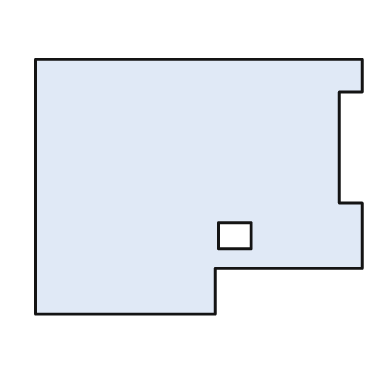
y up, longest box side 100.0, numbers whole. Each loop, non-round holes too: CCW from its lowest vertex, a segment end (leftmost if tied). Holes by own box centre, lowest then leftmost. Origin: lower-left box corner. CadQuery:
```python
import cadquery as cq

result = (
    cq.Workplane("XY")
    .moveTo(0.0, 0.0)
    .lineTo(55.0, 0.0)
    .lineTo(55.0, 14.0)
    .lineTo(100.0, 14.0)
    .lineTo(100.0, 34.0)
    .lineTo(93.0, 34.0)
    .lineTo(93.0, 68.0)
    .lineTo(100.0, 68.0)
    .lineTo(100.0, 78.0)
    .lineTo(0.0, 78.0)
    .close()
    .moveTo(56.0, 20.0)
    .lineTo(66.0, 20.0)
    .lineTo(66.0, 28.0)
    .lineTo(56.0, 28.0)
    .close()
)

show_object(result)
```